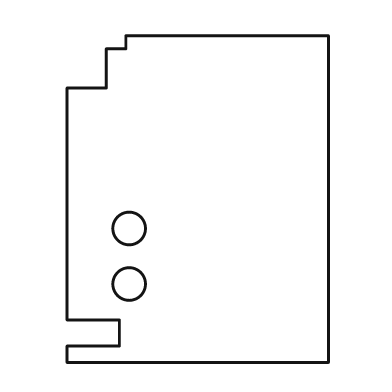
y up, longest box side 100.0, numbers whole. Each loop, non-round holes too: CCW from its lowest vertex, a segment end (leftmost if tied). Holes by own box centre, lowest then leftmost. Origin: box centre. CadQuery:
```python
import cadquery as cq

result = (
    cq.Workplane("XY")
    .moveTo(-40.0, -50.0)
    .lineTo(40.0, -50.0)
    .lineTo(40.0, 50.0)
    .lineTo(-22.0, 50.0)
    .lineTo(-22.0, 46.0)
    .lineTo(-28.0, 46.0)
    .lineTo(-28.0, 34.0)
    .lineTo(-40.0, 34.0)
    .lineTo(-40.0, -37.0)
    .lineTo(-24.0, -37.0)
    .lineTo(-24.0, -45.0)
    .lineTo(-40.0, -45.0)
    .close()
    .moveTo(-21.0, -26.0)
    .circle(5.0)
    .moveTo(-21.0, -9.0)
    .circle(5.0)
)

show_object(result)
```